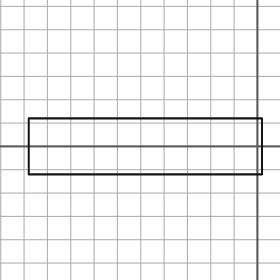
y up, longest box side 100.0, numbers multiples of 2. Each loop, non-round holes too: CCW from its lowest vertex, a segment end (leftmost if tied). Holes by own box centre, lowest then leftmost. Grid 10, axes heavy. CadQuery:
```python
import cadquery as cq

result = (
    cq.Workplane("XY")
    .moveTo(-98.0, -12.0)
    .lineTo(2.0, -12.0)
    .lineTo(2.0, 12.0)
    .lineTo(-98.0, 12.0)
    .close()
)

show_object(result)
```